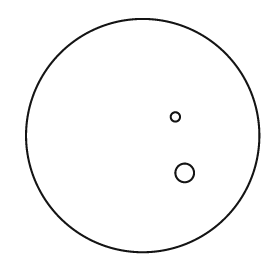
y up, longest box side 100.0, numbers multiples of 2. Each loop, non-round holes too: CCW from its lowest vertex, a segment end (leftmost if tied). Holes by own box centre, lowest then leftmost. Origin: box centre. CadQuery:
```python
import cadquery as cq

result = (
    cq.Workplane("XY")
    .moveTo(0.0, 0.0)
    .circle(50.0)
    .moveTo(18.0, -16.0)
    .circle(4.0)
    .moveTo(14.0, 8.0)
    .circle(2.0)
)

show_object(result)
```